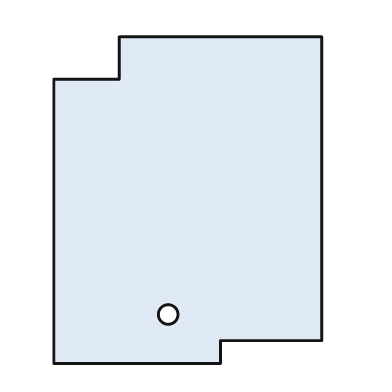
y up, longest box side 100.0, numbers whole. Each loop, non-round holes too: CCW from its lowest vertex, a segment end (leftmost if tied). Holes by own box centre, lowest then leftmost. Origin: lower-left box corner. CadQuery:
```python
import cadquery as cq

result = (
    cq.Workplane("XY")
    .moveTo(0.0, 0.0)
    .lineTo(51.0, 0.0)
    .lineTo(51.0, 7.0)
    .lineTo(82.0, 7.0)
    .lineTo(82.0, 100.0)
    .lineTo(20.0, 100.0)
    .lineTo(20.0, 87.0)
    .lineTo(0.0, 87.0)
    .close()
    .moveTo(35.0, 15.0)
    .circle(3.0)
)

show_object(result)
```